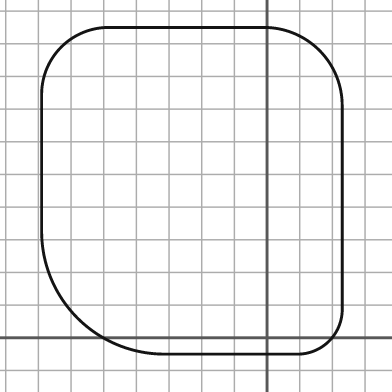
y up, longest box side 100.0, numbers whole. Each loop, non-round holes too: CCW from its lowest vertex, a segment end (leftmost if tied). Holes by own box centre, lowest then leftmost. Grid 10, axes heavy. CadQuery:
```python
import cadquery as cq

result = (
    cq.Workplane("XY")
    .moveTo(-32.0, -5.0)
    .lineTo(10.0, -5.0)
    .threePointArc((19.0, -1.0), (23.0, 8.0))
    .lineTo(23.0, 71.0)
    .threePointArc((16.0, 88.0), (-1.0, 95.0))
    .lineTo(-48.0, 95.0)
    .threePointArc((-63.0, 89.0), (-69.0, 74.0))
    .lineTo(-69.0, 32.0)
    .threePointArc((-58.0, 6.0), (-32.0, -5.0))
    .close()
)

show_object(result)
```